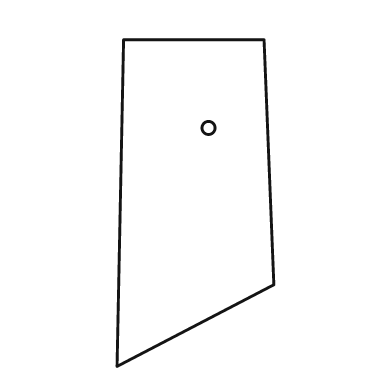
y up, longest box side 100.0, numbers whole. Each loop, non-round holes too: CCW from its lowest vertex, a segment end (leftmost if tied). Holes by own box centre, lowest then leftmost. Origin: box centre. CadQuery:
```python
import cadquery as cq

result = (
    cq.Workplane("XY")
    .moveTo(-24.0, -50.0)
    .lineTo(24.0, -25.0)
    .lineTo(21.0, 50.0)
    .lineTo(-22.0, 50.0)
    .close()
    .moveTo(4.0, 23.0)
    .circle(2.0)
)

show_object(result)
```